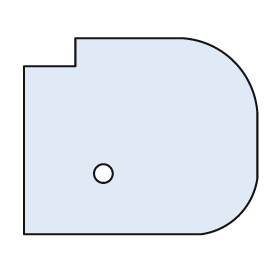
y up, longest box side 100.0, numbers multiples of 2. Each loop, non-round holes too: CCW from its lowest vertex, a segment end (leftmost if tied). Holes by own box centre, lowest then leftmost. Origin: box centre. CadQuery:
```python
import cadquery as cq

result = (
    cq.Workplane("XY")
    .moveTo(-50.0, -42.0)
    .lineTo(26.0, -42.0)
    .threePointArc((42.0, -34.0), (50.0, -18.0))
    .lineTo(50.0, 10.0)
    .threePointArc((40.0, 32.0), (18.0, 42.0))
    .lineTo(-28.0, 42.0)
    .lineTo(-28.0, 30.0)
    .lineTo(-50.0, 30.0)
    .close()
    .moveTo(-16.0, -16.0)
    .circle(4.0)
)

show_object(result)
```